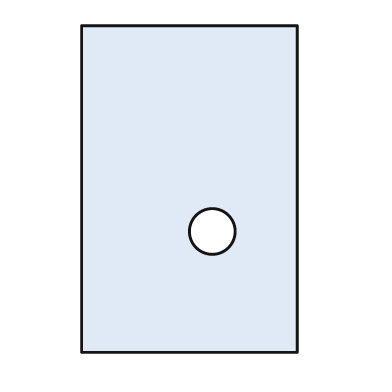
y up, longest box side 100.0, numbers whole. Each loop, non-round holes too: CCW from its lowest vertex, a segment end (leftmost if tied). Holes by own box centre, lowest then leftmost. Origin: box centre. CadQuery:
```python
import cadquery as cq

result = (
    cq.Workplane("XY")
    .moveTo(-33.0, -50.0)
    .lineTo(33.0, -50.0)
    .lineTo(33.0, 50.0)
    .lineTo(-33.0, 50.0)
    .close()
    .moveTo(7.0, -13.0)
    .circle(7.0)
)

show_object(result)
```